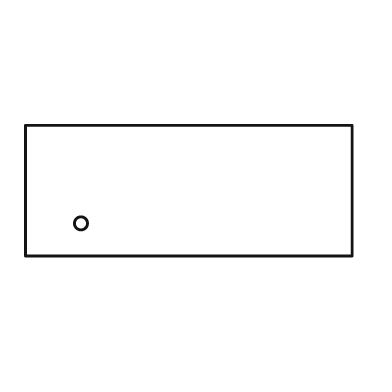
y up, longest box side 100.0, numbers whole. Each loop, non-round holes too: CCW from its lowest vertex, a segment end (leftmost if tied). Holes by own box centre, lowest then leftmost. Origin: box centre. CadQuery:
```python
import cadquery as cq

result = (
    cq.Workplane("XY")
    .moveTo(-50.0, -20.0)
    .lineTo(50.0, -20.0)
    .lineTo(50.0, 20.0)
    .lineTo(-50.0, 20.0)
    .close()
    .moveTo(-33.0, -10.0)
    .circle(2.0)
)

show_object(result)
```